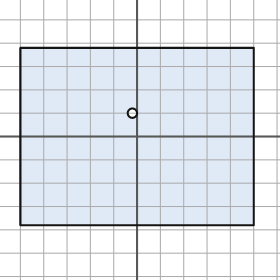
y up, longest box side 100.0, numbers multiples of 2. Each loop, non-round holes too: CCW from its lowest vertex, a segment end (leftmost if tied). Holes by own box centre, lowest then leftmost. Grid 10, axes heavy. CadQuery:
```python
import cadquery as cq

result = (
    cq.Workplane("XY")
    .moveTo(-50.0, -38.0)
    .lineTo(50.0, -38.0)
    .lineTo(50.0, 38.0)
    .lineTo(-50.0, 38.0)
    .close()
    .moveTo(-2.0, 10.0)
    .circle(2.0)
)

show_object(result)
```